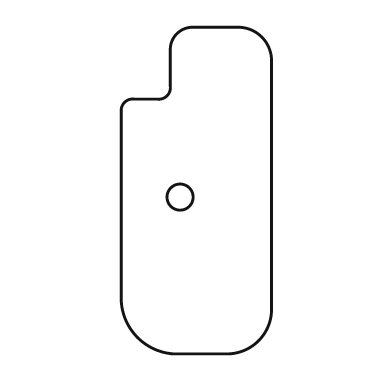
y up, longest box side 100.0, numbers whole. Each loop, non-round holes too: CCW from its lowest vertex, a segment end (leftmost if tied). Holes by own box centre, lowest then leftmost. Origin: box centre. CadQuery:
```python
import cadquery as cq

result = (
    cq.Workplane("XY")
    .moveTo(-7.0, -50.0)
    .lineTo(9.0, -50.0)
    .threePointArc((19.0, -46.0), (23.0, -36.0))
    .lineTo(23.0, 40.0)
    .threePointArc((20.0, 47.0), (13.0, 50.0))
    .lineTo(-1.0, 50.0)
    .threePointArc((-6.0, 48.0), (-8.0, 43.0))
    .lineTo(-8.0, 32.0)
    .threePointArc((-9.0, 29.0), (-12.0, 28.0))
    .lineTo(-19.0, 28.0)
    .threePointArc((-22.0, 27.0), (-23.0, 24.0))
    .lineTo(-23.0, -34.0)
    .threePointArc((-18.0, -45.0), (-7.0, -50.0))
    .close()
    .moveTo(-5.0, -2.0)
    .circle(4.0)
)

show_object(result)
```